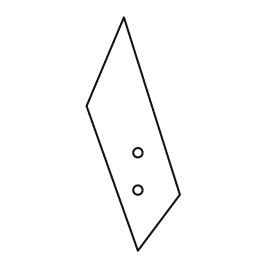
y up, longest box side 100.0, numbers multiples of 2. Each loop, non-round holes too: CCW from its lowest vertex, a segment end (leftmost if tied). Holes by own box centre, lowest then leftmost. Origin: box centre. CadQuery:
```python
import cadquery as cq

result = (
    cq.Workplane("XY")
    .moveTo(2.0, -50.0)
    .lineTo(20.0, -26.0)
    .lineTo(-4.0, 50.0)
    .lineTo(-20.0, 12.0)
    .close()
    .moveTo(2.0, -24.0)
    .circle(2.0)
    .moveTo(2.0, -8.0)
    .circle(2.0)
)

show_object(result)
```